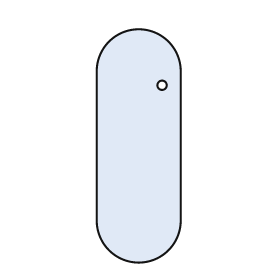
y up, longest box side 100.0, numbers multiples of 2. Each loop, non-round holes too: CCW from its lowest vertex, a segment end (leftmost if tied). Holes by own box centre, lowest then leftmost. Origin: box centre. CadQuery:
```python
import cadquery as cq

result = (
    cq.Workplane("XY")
    .moveTo(-18.0, -32.0)
    .threePointArc((0.0, -50.0), (18.0, -32.0))
    .lineTo(18.0, 32.0)
    .threePointArc((0.0, 50.0), (-18.0, 32.0))
    .close()
    .moveTo(10.0, 26.0)
    .circle(2.0)
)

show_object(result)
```